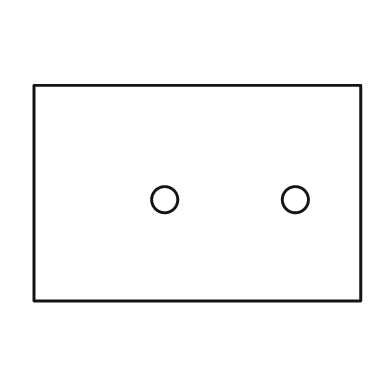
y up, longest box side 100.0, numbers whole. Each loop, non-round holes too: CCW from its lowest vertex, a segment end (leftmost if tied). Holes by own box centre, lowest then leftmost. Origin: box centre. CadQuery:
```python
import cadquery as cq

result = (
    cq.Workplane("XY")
    .moveTo(-50.0, -33.0)
    .lineTo(50.0, -33.0)
    .lineTo(50.0, 33.0)
    .lineTo(-50.0, 33.0)
    .close()
    .moveTo(-10.0, -2.0)
    .circle(4.0)
    .moveTo(30.0, -2.0)
    .circle(4.0)
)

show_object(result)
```